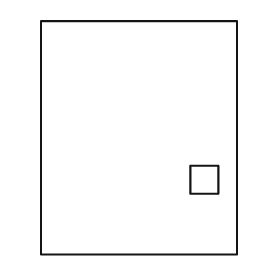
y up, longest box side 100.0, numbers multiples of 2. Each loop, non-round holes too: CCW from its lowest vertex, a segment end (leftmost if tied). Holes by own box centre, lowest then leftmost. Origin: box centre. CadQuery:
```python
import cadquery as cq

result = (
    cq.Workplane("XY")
    .moveTo(-42.0, -50.0)
    .lineTo(42.0, -50.0)
    .lineTo(42.0, 50.0)
    .lineTo(-42.0, 50.0)
    .close()
    .moveTo(22.0, -24.0)
    .lineTo(34.0, -24.0)
    .lineTo(34.0, -12.0)
    .lineTo(22.0, -12.0)
    .close()
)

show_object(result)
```